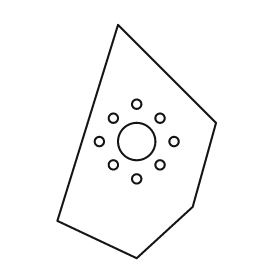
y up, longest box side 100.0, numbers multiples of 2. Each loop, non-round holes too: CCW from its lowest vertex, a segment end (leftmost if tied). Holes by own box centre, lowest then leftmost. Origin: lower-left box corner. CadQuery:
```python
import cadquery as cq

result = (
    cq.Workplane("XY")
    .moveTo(34.0, 0.0)
    .lineTo(58.0, 22.0)
    .lineTo(68.0, 58.0)
    .lineTo(26.0, 100.0)
    .lineTo(0.0, 16.0)
    .close()
    .moveTo(34.0, 34.0)
    .circle(2.0)
    .moveTo(24.0, 40.0)
    .circle(2.0)
    .moveTo(44.0, 40.0)
    .circle(2.0)
    .moveTo(18.0, 50.0)
    .circle(2.0)
    .moveTo(34.0, 50.0)
    .circle(8.0)
    .moveTo(50.0, 50.0)
    .circle(2.0)
    .moveTo(24.0, 60.0)
    .circle(2.0)
    .moveTo(44.0, 60.0)
    .circle(2.0)
    .moveTo(34.0, 66.0)
    .circle(2.0)
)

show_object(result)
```